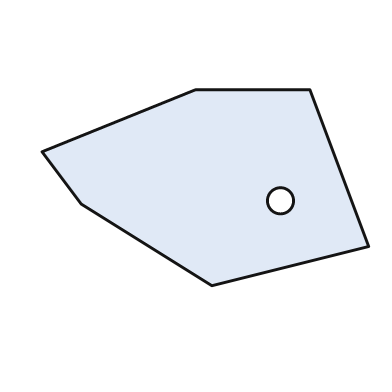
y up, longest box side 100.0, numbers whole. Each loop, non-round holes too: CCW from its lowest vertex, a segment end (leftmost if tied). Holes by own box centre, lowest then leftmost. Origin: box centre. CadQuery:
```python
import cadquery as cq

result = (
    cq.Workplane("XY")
    .moveTo(2.0, -30.0)
    .lineTo(50.0, -18.0)
    .lineTo(32.0, 30.0)
    .lineTo(-3.0, 30.0)
    .lineTo(-50.0, 11.0)
    .lineTo(-38.0, -5.0)
    .close()
    .moveTo(23.0, -4.0)
    .circle(4.0)
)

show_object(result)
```